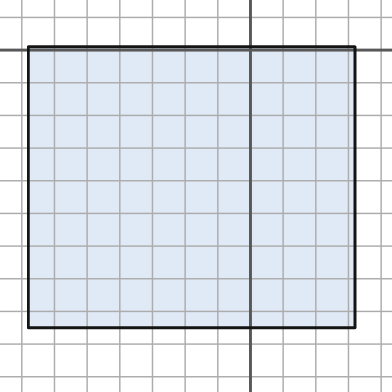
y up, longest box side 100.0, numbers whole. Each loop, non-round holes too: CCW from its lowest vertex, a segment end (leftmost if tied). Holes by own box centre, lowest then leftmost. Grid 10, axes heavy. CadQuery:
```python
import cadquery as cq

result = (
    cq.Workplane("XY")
    .moveTo(-68.0, -85.0)
    .lineTo(32.0, -85.0)
    .lineTo(32.0, 1.0)
    .lineTo(-68.0, 1.0)
    .close()
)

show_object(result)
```